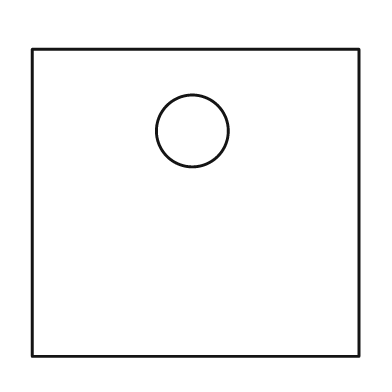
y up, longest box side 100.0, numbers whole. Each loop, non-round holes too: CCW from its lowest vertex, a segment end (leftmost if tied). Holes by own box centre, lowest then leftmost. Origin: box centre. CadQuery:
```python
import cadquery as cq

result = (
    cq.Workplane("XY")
    .moveTo(-50.0, -47.0)
    .lineTo(50.0, -47.0)
    .lineTo(50.0, 47.0)
    .lineTo(-50.0, 47.0)
    .close()
    .moveTo(-1.0, 22.0)
    .circle(11.0)
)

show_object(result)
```